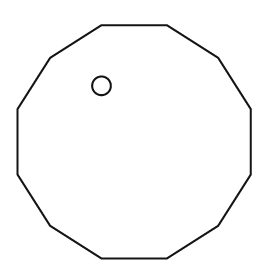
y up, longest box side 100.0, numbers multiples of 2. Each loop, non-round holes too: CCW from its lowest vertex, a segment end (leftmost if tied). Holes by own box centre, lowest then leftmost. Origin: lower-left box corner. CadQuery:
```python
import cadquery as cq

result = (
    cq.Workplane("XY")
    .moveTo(36.0, 0.0)
    .lineTo(64.0, 0.0)
    .lineTo(86.0, 14.0)
    .lineTo(100.0, 36.0)
    .lineTo(100.0, 64.0)
    .lineTo(86.0, 86.0)
    .lineTo(64.0, 100.0)
    .lineTo(36.0, 100.0)
    .lineTo(14.0, 86.0)
    .lineTo(0.0, 64.0)
    .lineTo(0.0, 36.0)
    .lineTo(14.0, 14.0)
    .close()
    .moveTo(36.0, 74.0)
    .circle(4.0)
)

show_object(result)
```